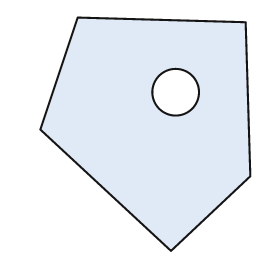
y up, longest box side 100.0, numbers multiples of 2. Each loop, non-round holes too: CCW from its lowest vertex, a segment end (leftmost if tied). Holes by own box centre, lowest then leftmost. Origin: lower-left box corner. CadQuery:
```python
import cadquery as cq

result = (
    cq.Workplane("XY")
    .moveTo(56.0, 0.0)
    .lineTo(90.0, 32.0)
    .lineTo(88.0, 98.0)
    .lineTo(16.0, 100.0)
    .lineTo(0.0, 52.0)
    .close()
    .moveTo(58.0, 68.0)
    .circle(10.0)
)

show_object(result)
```